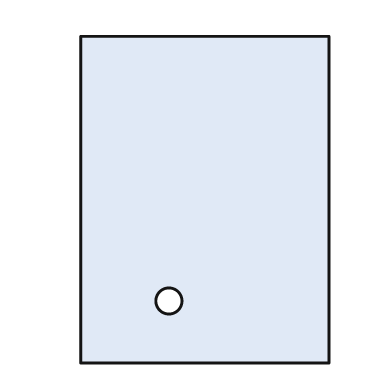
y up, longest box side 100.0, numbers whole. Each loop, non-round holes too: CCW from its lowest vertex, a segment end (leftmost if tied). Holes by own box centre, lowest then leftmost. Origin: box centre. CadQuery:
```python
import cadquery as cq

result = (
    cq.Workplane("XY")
    .moveTo(-38.0, -50.0)
    .lineTo(38.0, -50.0)
    .lineTo(38.0, 50.0)
    .lineTo(-38.0, 50.0)
    .close()
    .moveTo(-11.0, -31.0)
    .circle(4.0)
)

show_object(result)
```